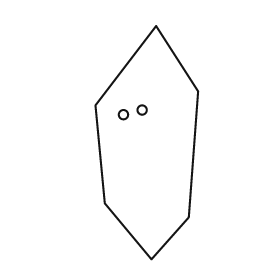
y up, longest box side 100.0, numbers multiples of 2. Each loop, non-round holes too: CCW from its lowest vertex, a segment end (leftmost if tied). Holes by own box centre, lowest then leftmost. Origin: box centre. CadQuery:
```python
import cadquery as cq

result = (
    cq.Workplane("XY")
    .moveTo(2.0, -50.0)
    .lineTo(18.0, -32.0)
    .lineTo(22.0, 22.0)
    .lineTo(4.0, 50.0)
    .lineTo(-22.0, 16.0)
    .lineTo(-18.0, -26.0)
    .close()
    .moveTo(-10.0, 12.0)
    .circle(2.0)
    .moveTo(-2.0, 14.0)
    .circle(2.0)
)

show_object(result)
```